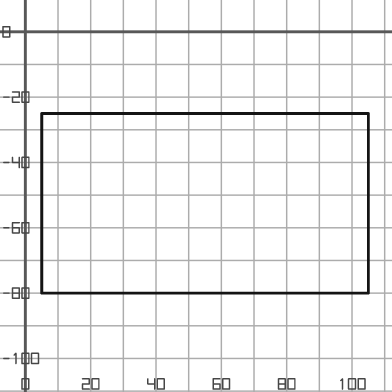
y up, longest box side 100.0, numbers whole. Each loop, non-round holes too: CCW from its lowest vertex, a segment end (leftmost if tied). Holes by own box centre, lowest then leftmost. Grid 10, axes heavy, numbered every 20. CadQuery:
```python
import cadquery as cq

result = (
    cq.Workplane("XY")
    .moveTo(5.0, -80.0)
    .lineTo(105.0, -80.0)
    .lineTo(105.0, -25.0)
    .lineTo(5.0, -25.0)
    .close()
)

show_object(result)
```